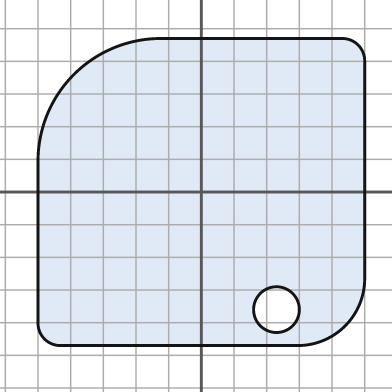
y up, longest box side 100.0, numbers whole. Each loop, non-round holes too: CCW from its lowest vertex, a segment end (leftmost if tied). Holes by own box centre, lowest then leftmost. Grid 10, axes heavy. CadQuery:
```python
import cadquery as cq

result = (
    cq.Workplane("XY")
    .moveTo(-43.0, -47.0)
    .lineTo(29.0, -47.0)
    .threePointArc((44.0, -41.0), (50.0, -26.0))
    .lineTo(50.0, 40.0)
    .threePointArc((48.0, 45.0), (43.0, 47.0))
    .lineTo(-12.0, 47.0)
    .threePointArc((-39.0, 36.0), (-50.0, 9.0))
    .lineTo(-50.0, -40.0)
    .threePointArc((-48.0, -45.0), (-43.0, -47.0))
    .close()
    .moveTo(23.0, -36.0)
    .circle(7.0)
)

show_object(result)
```